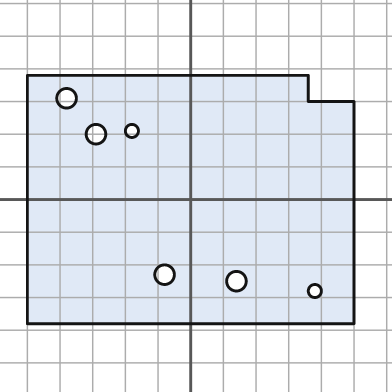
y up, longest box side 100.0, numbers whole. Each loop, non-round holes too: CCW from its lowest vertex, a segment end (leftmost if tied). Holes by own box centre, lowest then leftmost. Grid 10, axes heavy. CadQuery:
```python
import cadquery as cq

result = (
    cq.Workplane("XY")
    .moveTo(-50.0, -38.0)
    .lineTo(50.0, -38.0)
    .lineTo(50.0, 30.0)
    .lineTo(36.0, 30.0)
    .lineTo(36.0, 38.0)
    .lineTo(-50.0, 38.0)
    .close()
    .moveTo(38.0, -28.0)
    .circle(2.0)
    .moveTo(14.0, -25.0)
    .circle(3.0)
    .moveTo(-8.0, -23.0)
    .circle(3.0)
    .moveTo(-29.0, 20.0)
    .circle(3.0)
    .moveTo(-18.0, 21.0)
    .circle(2.0)
    .moveTo(-38.0, 31.0)
    .circle(3.0)
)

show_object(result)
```